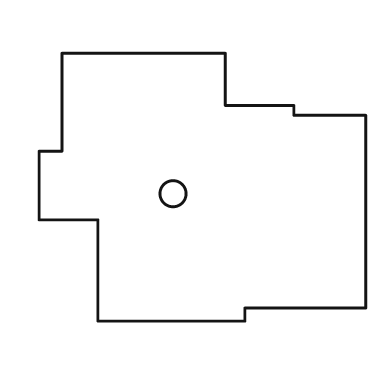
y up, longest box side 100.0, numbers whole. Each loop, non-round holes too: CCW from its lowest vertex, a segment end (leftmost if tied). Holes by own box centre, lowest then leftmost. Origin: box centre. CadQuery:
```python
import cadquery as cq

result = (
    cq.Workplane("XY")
    .moveTo(-32.0, -41.0)
    .lineTo(13.0, -41.0)
    .lineTo(13.0, -37.0)
    .lineTo(50.0, -37.0)
    .lineTo(50.0, 22.0)
    .lineTo(28.0, 22.0)
    .lineTo(28.0, 25.0)
    .lineTo(7.0, 25.0)
    .lineTo(7.0, 41.0)
    .lineTo(-43.0, 41.0)
    .lineTo(-43.0, 11.0)
    .lineTo(-50.0, 11.0)
    .lineTo(-50.0, -10.0)
    .lineTo(-32.0, -10.0)
    .close()
    .moveTo(-9.0, -2.0)
    .circle(4.0)
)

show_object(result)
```